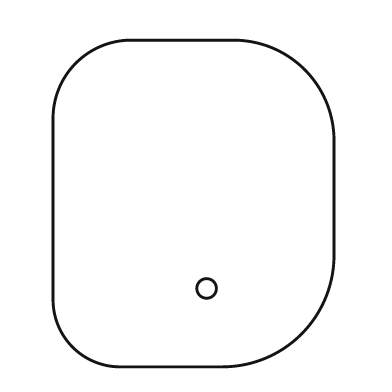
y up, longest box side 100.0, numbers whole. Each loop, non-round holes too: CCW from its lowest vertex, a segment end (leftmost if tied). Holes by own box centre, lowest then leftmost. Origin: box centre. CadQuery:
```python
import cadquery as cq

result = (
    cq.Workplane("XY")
    .moveTo(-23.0, -50.0)
    .lineTo(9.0, -50.0)
    .threePointArc((33.0, -40.0), (43.0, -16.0))
    .lineTo(43.0, 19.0)
    .threePointArc((34.0, 41.0), (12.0, 50.0))
    .lineTo(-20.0, 50.0)
    .threePointArc((-36.0, 43.0), (-43.0, 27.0))
    .lineTo(-43.0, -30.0)
    .threePointArc((-37.0, -44.0), (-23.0, -50.0))
    .close()
    .moveTo(4.0, -26.0)
    .circle(3.0)
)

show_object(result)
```